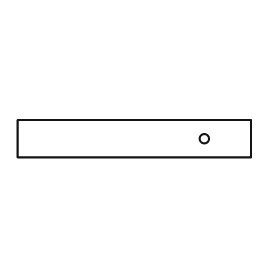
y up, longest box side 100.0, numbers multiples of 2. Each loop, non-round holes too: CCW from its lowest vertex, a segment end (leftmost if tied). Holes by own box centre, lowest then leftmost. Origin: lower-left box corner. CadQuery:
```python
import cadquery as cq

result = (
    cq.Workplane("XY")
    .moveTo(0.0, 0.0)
    .lineTo(100.0, 0.0)
    .lineTo(100.0, 16.0)
    .lineTo(0.0, 16.0)
    .close()
    .moveTo(80.0, 8.0)
    .circle(2.0)
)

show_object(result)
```